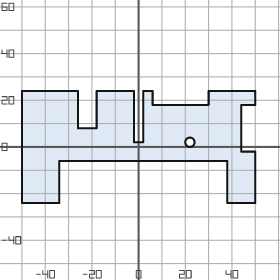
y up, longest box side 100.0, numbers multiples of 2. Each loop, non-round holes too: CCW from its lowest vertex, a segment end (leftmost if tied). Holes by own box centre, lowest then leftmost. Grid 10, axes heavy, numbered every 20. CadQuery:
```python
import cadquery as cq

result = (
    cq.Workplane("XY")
    .moveTo(-50.0, -24.0)
    .lineTo(-34.0, -24.0)
    .lineTo(-34.0, -6.0)
    .lineTo(38.0, -6.0)
    .lineTo(38.0, -24.0)
    .lineTo(50.0, -24.0)
    .lineTo(50.0, -2.0)
    .lineTo(44.0, -2.0)
    .lineTo(44.0, 18.0)
    .lineTo(50.0, 18.0)
    .lineTo(50.0, 24.0)
    .lineTo(30.0, 24.0)
    .lineTo(30.0, 18.0)
    .lineTo(6.0, 18.0)
    .lineTo(6.0, 24.0)
    .lineTo(2.0, 24.0)
    .lineTo(2.0, 2.0)
    .lineTo(-2.0, 2.0)
    .lineTo(-2.0, 24.0)
    .lineTo(-18.0, 24.0)
    .lineTo(-18.0, 8.0)
    .lineTo(-26.0, 8.0)
    .lineTo(-26.0, 24.0)
    .lineTo(-50.0, 24.0)
    .close()
    .moveTo(22.0, 2.0)
    .circle(2.0)
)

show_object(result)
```